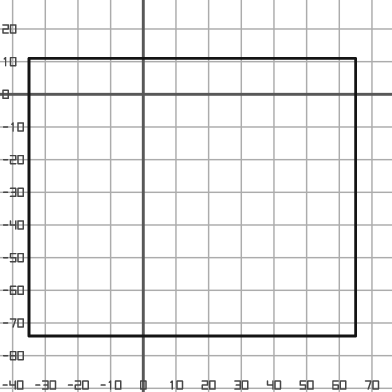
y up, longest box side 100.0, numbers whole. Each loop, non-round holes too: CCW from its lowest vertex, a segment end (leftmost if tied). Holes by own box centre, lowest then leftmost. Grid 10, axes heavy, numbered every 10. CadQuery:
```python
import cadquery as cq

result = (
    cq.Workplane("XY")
    .moveTo(-35.0, -74.0)
    .lineTo(65.0, -74.0)
    .lineTo(65.0, 11.0)
    .lineTo(-35.0, 11.0)
    .close()
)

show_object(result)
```